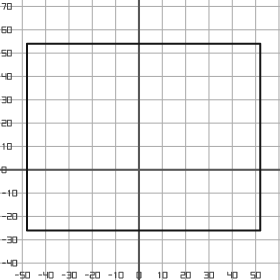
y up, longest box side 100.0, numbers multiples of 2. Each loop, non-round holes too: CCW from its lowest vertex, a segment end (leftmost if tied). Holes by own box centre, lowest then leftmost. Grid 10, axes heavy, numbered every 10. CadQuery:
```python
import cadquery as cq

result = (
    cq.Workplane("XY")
    .moveTo(-48.0, -26.0)
    .lineTo(52.0, -26.0)
    .lineTo(52.0, 54.0)
    .lineTo(-48.0, 54.0)
    .close()
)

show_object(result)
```